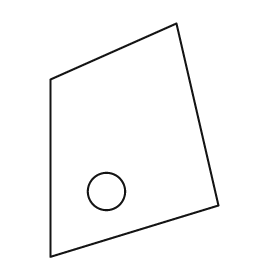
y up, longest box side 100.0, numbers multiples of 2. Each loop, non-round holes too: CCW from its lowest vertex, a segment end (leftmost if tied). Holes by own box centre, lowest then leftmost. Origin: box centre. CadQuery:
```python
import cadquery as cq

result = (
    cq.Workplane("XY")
    .moveTo(-36.0, -50.0)
    .lineTo(36.0, -28.0)
    .lineTo(18.0, 50.0)
    .lineTo(-36.0, 26.0)
    .close()
    .moveTo(-12.0, -22.0)
    .circle(8.0)
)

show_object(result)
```